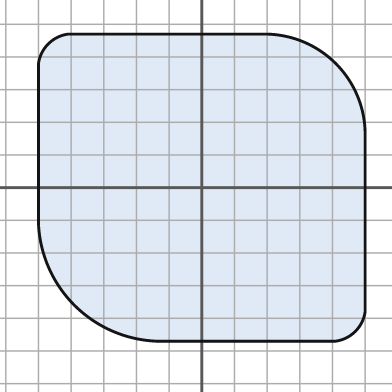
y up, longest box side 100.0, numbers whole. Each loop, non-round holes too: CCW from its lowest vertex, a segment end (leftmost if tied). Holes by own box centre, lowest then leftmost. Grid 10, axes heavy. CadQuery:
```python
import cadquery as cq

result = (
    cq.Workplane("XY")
    .moveTo(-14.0, -47.0)
    .lineTo(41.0, -47.0)
    .threePointArc((47.0, -44.0), (50.0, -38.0))
    .lineTo(50.0, 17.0)
    .threePointArc((41.0, 38.0), (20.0, 47.0))
    .lineTo(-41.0, 47.0)
    .threePointArc((-47.0, 44.0), (-50.0, 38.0))
    .lineTo(-50.0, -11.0)
    .threePointArc((-39.0, -36.0), (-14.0, -47.0))
    .close()
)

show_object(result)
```